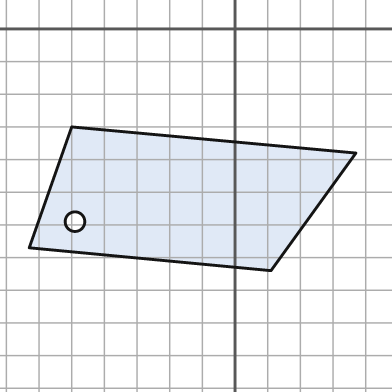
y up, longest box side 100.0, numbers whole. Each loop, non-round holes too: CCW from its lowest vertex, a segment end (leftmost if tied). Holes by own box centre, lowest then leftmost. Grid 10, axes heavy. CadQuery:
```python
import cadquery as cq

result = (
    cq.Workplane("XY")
    .moveTo(11.0, -74.0)
    .lineTo(37.0, -38.0)
    .lineTo(-50.0, -30.0)
    .lineTo(-63.0, -67.0)
    .close()
    .moveTo(-49.0, -59.0)
    .circle(3.0)
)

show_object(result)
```